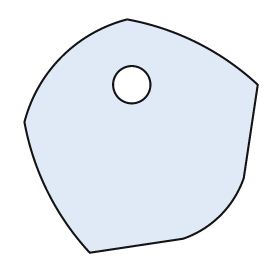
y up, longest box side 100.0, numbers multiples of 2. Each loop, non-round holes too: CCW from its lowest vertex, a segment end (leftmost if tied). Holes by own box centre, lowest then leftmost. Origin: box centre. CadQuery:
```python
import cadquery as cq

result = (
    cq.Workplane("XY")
    .moveTo(-22.0, -50.0)
    .lineTo(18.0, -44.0)
    .threePointArc((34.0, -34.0), (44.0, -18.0))
    .lineTo(50.0, 22.0)
    .threePointArc((24.0, 40.0), (-6.0, 50.0))
    .threePointArc((-34.0, 34.0), (-50.0, 6.0))
    .threePointArc((-40.0, -24.0), (-22.0, -50.0))
    .close()
    .moveTo(-4.0, 22.0)
    .circle(8.0)
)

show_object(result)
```